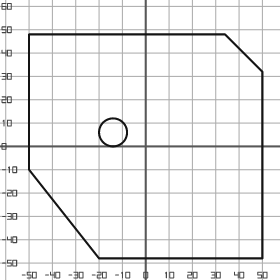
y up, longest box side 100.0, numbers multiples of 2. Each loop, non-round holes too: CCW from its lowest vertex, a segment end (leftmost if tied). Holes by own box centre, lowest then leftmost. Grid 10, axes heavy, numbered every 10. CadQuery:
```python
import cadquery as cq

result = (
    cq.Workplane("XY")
    .moveTo(-20.0, -48.0)
    .lineTo(50.0, -48.0)
    .lineTo(50.0, 32.0)
    .lineTo(34.0, 48.0)
    .lineTo(-50.0, 48.0)
    .lineTo(-50.0, -10.0)
    .close()
    .moveTo(-14.0, 6.0)
    .circle(6.0)
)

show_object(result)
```